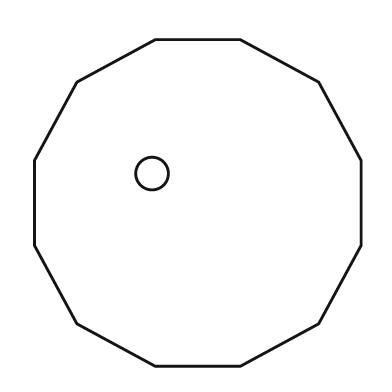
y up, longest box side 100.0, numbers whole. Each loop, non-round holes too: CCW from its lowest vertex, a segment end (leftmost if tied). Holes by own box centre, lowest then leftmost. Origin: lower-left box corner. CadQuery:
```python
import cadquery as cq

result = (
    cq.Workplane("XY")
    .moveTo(37.0, 0.0)
    .lineTo(63.0, 0.0)
    .lineTo(87.0, 13.0)
    .lineTo(100.0, 37.0)
    .lineTo(100.0, 63.0)
    .lineTo(87.0, 87.0)
    .lineTo(63.0, 100.0)
    .lineTo(37.0, 100.0)
    .lineTo(13.0, 87.0)
    .lineTo(0.0, 63.0)
    .lineTo(0.0, 37.0)
    .lineTo(13.0, 13.0)
    .close()
    .moveTo(36.0, 59.0)
    .circle(5.0)
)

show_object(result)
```